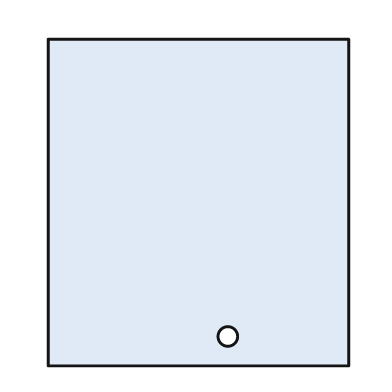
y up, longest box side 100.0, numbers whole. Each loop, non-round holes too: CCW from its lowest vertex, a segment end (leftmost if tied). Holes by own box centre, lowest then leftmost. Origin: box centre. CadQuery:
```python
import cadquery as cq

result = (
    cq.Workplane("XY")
    .moveTo(-46.0, -50.0)
    .lineTo(46.0, -50.0)
    .lineTo(46.0, 50.0)
    .lineTo(-46.0, 50.0)
    .close()
    .moveTo(9.0, -41.0)
    .circle(3.0)
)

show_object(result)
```